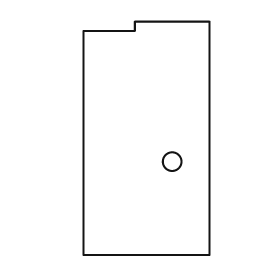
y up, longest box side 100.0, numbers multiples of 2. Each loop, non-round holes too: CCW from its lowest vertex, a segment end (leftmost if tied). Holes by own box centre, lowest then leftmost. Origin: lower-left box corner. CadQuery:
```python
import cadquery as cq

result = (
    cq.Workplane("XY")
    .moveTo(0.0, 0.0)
    .lineTo(54.0, 0.0)
    .lineTo(54.0, 100.0)
    .lineTo(22.0, 100.0)
    .lineTo(22.0, 96.0)
    .lineTo(0.0, 96.0)
    .close()
    .moveTo(38.0, 40.0)
    .circle(4.0)
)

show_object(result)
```